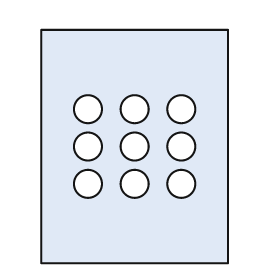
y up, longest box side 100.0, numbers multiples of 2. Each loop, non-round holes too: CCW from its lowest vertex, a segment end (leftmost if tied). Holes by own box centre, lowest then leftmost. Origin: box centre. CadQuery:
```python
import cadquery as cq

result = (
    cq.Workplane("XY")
    .moveTo(-40.0, -50.0)
    .lineTo(40.0, -50.0)
    .lineTo(40.0, 50.0)
    .lineTo(-40.0, 50.0)
    .close()
    .moveTo(-20.0, -16.0)
    .circle(6.0)
    .moveTo(0.0, -16.0)
    .circle(6.0)
    .moveTo(20.0, -16.0)
    .circle(6.0)
    .moveTo(-20.0, 0.0)
    .circle(6.0)
    .moveTo(0.0, 0.0)
    .circle(6.0)
    .moveTo(20.0, 0.0)
    .circle(6.0)
    .moveTo(-20.0, 16.0)
    .circle(6.0)
    .moveTo(0.0, 16.0)
    .circle(6.0)
    .moveTo(20.0, 16.0)
    .circle(6.0)
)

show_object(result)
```